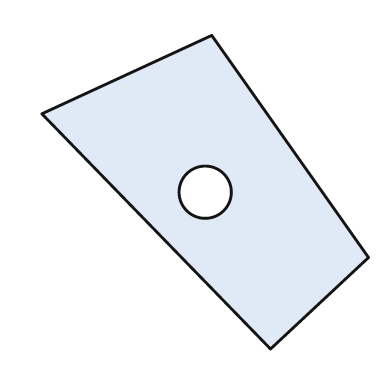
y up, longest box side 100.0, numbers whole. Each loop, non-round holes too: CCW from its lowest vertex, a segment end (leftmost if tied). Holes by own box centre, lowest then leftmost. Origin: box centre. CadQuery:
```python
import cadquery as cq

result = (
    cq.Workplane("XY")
    .moveTo(20.0, -48.0)
    .lineTo(50.0, -20.0)
    .lineTo(2.0, 48.0)
    .lineTo(-50.0, 24.0)
    .close()
    .moveTo(0.0, 0.0)
    .circle(8.0)
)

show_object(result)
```